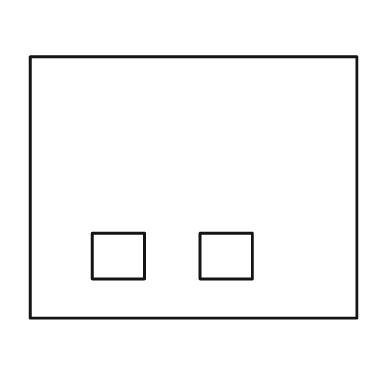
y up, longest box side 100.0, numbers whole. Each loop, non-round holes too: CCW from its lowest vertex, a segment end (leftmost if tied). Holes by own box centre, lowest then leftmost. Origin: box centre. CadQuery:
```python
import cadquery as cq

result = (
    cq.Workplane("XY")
    .moveTo(-50.0, -40.0)
    .lineTo(50.0, -40.0)
    .lineTo(50.0, 40.0)
    .lineTo(-50.0, 40.0)
    .close()
    .moveTo(-31.0, -28.0)
    .lineTo(-15.0, -28.0)
    .lineTo(-15.0, -14.0)
    .lineTo(-31.0, -14.0)
    .close()
    .moveTo(2.0, -28.0)
    .lineTo(18.0, -28.0)
    .lineTo(18.0, -14.0)
    .lineTo(2.0, -14.0)
    .close()
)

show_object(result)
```